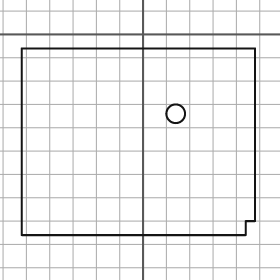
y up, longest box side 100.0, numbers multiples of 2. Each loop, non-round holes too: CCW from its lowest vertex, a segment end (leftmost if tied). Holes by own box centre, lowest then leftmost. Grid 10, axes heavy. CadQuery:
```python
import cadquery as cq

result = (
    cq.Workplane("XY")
    .moveTo(-52.0, -86.0)
    .lineTo(44.0, -86.0)
    .lineTo(44.0, -80.0)
    .lineTo(48.0, -80.0)
    .lineTo(48.0, -6.0)
    .lineTo(-52.0, -6.0)
    .close()
    .moveTo(14.0, -34.0)
    .circle(4.0)
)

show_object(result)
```